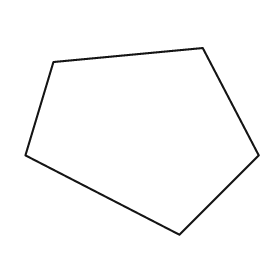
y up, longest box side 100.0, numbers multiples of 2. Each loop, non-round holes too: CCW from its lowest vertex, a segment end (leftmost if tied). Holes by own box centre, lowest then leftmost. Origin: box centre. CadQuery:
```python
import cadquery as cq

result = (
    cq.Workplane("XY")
    .moveTo(16.0, -40.0)
    .lineTo(50.0, -6.0)
    .lineTo(26.0, 40.0)
    .lineTo(-38.0, 34.0)
    .lineTo(-50.0, -6.0)
    .close()
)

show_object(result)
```